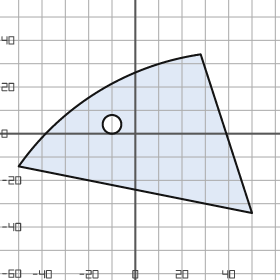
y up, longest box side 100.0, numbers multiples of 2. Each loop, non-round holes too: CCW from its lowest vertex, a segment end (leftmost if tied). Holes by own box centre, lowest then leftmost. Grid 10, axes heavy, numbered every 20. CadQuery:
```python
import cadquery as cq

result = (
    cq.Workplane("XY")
    .moveTo(50.0, -34.0)
    .lineTo(28.0, 34.0)
    .threePointArc((-16.0, 18.0), (-50.0, -14.0))
    .close()
    .moveTo(-10.0, 4.0)
    .circle(4.0)
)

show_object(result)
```